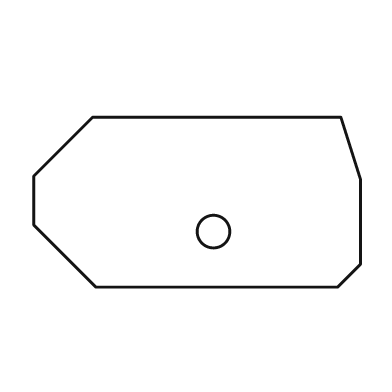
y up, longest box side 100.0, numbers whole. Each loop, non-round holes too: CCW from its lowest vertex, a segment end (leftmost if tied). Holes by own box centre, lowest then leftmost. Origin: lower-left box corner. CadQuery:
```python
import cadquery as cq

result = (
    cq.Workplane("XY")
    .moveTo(19.0, 0.0)
    .lineTo(93.0, 0.0)
    .lineTo(100.0, 7.0)
    .lineTo(100.0, 33.0)
    .lineTo(94.0, 52.0)
    .lineTo(18.0, 52.0)
    .lineTo(0.0, 34.0)
    .lineTo(0.0, 19.0)
    .close()
    .moveTo(55.0, 17.0)
    .circle(5.0)
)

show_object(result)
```